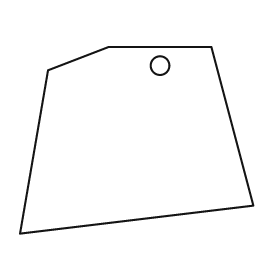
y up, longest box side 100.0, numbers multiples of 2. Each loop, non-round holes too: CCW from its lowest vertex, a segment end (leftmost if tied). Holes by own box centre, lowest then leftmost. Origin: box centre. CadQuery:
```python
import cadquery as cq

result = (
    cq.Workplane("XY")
    .moveTo(-50.0, -40.0)
    .lineTo(50.0, -28.0)
    .lineTo(32.0, 40.0)
    .lineTo(-12.0, 40.0)
    .lineTo(-38.0, 30.0)
    .close()
    .moveTo(10.0, 32.0)
    .circle(4.0)
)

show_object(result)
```